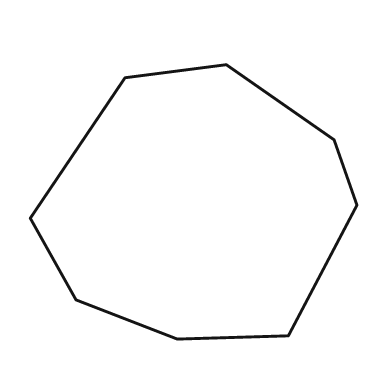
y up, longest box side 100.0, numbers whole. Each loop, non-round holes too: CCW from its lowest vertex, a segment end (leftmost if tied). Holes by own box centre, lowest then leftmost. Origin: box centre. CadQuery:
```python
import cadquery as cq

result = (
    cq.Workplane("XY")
    .moveTo(-5.0, -42.0)
    .lineTo(29.0, -41.0)
    .lineTo(50.0, -1.0)
    .lineTo(43.0, 19.0)
    .lineTo(10.0, 42.0)
    .lineTo(-21.0, 38.0)
    .lineTo(-50.0, -5.0)
    .lineTo(-36.0, -30.0)
    .close()
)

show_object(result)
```